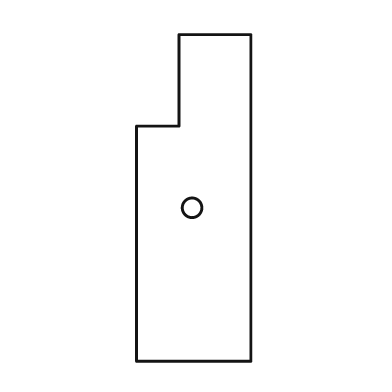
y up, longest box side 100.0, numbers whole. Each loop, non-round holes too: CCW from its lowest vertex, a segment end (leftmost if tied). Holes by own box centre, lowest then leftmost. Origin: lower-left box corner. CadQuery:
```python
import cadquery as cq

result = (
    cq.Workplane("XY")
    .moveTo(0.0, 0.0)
    .lineTo(35.0, 0.0)
    .lineTo(35.0, 100.0)
    .lineTo(13.0, 100.0)
    .lineTo(13.0, 72.0)
    .lineTo(0.0, 72.0)
    .close()
    .moveTo(17.0, 47.0)
    .circle(3.0)
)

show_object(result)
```